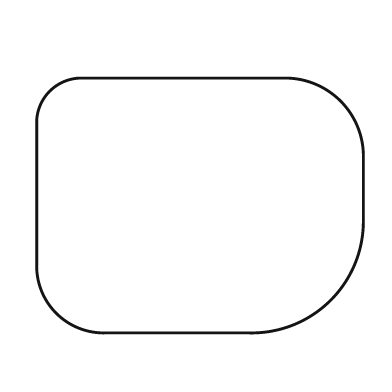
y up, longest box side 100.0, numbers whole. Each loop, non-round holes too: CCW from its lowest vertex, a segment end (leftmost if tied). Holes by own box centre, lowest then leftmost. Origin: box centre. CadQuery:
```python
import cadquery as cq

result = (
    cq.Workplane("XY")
    .moveTo(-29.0, -39.0)
    .lineTo(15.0, -39.0)
    .threePointArc((40.0, -29.0), (50.0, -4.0))
    .lineTo(50.0, 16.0)
    .threePointArc((43.0, 32.0), (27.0, 39.0))
    .lineTo(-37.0, 39.0)
    .threePointArc((-46.0, 35.0), (-50.0, 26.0))
    .lineTo(-50.0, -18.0)
    .threePointArc((-44.0, -33.0), (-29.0, -39.0))
    .close()
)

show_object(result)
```